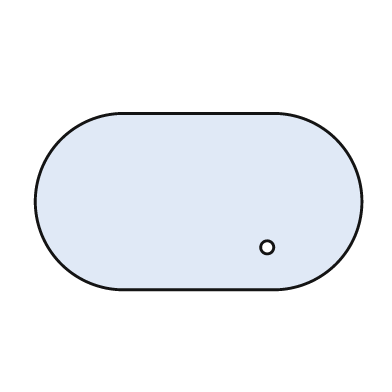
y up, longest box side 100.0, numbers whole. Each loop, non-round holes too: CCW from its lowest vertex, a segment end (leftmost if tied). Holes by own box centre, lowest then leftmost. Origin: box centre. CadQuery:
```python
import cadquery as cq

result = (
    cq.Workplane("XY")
    .moveTo(-23.0, -27.0)
    .lineTo(23.0, -27.0)
    .threePointArc((50.0, 0.0), (23.0, 27.0))
    .lineTo(-23.0, 27.0)
    .threePointArc((-50.0, 0.0), (-23.0, -27.0))
    .close()
    .moveTo(21.0, -14.0)
    .circle(2.0)
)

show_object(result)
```